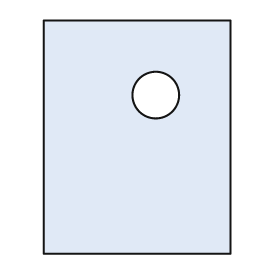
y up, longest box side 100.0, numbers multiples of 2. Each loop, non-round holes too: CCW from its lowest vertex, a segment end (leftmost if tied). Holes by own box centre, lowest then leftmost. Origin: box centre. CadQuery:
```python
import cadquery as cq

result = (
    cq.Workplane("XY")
    .moveTo(-40.0, -50.0)
    .lineTo(40.0, -50.0)
    .lineTo(40.0, 50.0)
    .lineTo(-40.0, 50.0)
    .close()
    .moveTo(8.0, 18.0)
    .circle(10.0)
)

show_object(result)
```